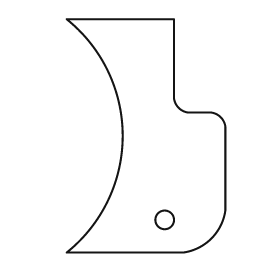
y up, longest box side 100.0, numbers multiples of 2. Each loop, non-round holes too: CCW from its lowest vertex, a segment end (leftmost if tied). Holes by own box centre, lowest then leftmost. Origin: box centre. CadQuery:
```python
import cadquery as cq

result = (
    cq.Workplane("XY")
    .moveTo(-34.0, -50.0)
    .lineTo(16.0, -50.0)
    .threePointArc((28.0, -44.0), (34.0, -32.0))
    .lineTo(34.0, 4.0)
    .threePointArc((32.0, 8.0), (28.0, 10.0))
    .lineTo(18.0, 10.0)
    .threePointArc((14.0, 12.0), (12.0, 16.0))
    .lineTo(12.0, 50.0)
    .lineTo(-34.0, 50.0)
    .threePointArc((-10.0, 0.0), (-34.0, -50.0))
    .close()
    .moveTo(8.0, -36.0)
    .circle(4.0)
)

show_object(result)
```